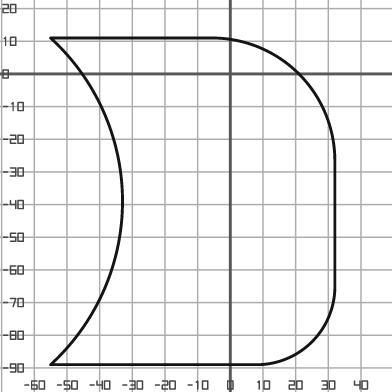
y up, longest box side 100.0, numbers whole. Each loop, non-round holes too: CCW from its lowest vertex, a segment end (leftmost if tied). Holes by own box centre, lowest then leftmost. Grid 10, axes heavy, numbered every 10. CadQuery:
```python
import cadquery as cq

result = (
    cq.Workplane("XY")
    .moveTo(-55.0, -89.0)
    .lineTo(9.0, -89.0)
    .threePointArc((25.0, -82.0), (32.0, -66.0))
    .lineTo(32.0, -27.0)
    .threePointArc((21.0, 0.0), (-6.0, 11.0))
    .lineTo(-55.0, 11.0)
    .threePointArc((-33.0, -39.0), (-55.0, -89.0))
    .close()
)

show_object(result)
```